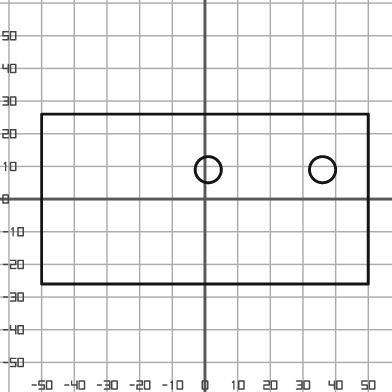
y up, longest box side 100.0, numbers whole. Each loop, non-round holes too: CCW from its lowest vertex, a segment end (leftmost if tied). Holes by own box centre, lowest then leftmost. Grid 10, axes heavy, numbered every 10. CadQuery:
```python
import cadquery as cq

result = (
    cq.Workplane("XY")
    .moveTo(-50.0, -26.0)
    .lineTo(50.0, -26.0)
    .lineTo(50.0, 26.0)
    .lineTo(-50.0, 26.0)
    .close()
    .moveTo(1.0, 9.0)
    .circle(4.0)
    .moveTo(36.0, 9.0)
    .circle(4.0)
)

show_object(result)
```